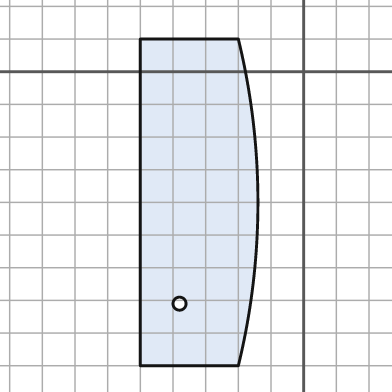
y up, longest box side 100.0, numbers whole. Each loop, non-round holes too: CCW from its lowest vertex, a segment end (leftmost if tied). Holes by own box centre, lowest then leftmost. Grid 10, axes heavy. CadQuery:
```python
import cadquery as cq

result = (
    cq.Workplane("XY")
    .moveTo(-50.0, -90.0)
    .lineTo(-20.0, -90.0)
    .threePointArc((-14.0, -40.0), (-20.0, 10.0))
    .lineTo(-50.0, 10.0)
    .close()
    .moveTo(-38.0, -71.0)
    .circle(2.0)
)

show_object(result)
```